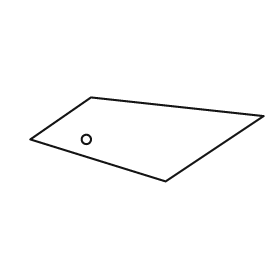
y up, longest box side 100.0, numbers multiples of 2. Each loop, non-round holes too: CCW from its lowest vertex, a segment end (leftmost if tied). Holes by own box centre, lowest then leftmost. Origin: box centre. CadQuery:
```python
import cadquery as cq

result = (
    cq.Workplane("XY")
    .moveTo(8.0, -18.0)
    .lineTo(50.0, 10.0)
    .lineTo(-24.0, 18.0)
    .lineTo(-50.0, 0.0)
    .close()
    .moveTo(-26.0, 0.0)
    .circle(2.0)
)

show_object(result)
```